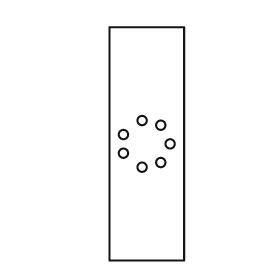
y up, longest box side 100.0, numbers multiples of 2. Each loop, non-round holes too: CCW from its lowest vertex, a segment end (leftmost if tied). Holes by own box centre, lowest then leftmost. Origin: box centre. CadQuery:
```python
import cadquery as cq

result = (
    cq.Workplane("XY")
    .moveTo(-16.0, -50.0)
    .lineTo(16.0, -50.0)
    .lineTo(16.0, 50.0)
    .lineTo(-16.0, 50.0)
    .close()
    .moveTo(-2.0, -10.0)
    .circle(2.0)
    .moveTo(6.0, -8.0)
    .circle(2.0)
    .moveTo(-10.0, -4.0)
    .circle(2.0)
    .moveTo(10.0, 0.0)
    .circle(2.0)
    .moveTo(-10.0, 4.0)
    .circle(2.0)
    .moveTo(6.0, 8.0)
    .circle(2.0)
    .moveTo(-2.0, 10.0)
    .circle(2.0)
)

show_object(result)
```